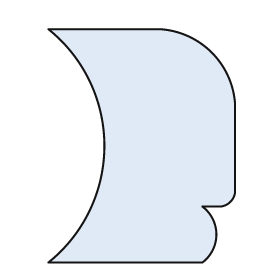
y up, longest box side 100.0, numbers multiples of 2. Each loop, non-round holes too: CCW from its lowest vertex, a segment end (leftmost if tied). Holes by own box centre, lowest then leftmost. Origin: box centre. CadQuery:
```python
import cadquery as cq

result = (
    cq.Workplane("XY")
    .moveTo(-40.0, -50.0)
    .lineTo(26.0, -50.0)
    .threePointArc((32.0, -38.0), (26.0, -26.0))
    .lineTo(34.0, -26.0)
    .threePointArc((38.0, -24.0), (40.0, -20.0))
    .lineTo(40.0, 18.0)
    .threePointArc((30.0, 40.0), (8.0, 50.0))
    .lineTo(-40.0, 50.0)
    .threePointArc((-16.0, 0.0), (-40.0, -50.0))
    .close()
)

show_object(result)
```